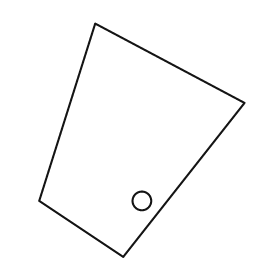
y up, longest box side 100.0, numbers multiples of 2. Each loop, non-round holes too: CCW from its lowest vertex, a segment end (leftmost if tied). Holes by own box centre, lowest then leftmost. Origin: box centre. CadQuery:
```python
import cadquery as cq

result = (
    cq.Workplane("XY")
    .moveTo(-8.0, -50.0)
    .lineTo(44.0, 16.0)
    .lineTo(-20.0, 50.0)
    .lineTo(-44.0, -26.0)
    .close()
    .moveTo(0.0, -26.0)
    .circle(4.0)
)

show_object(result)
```